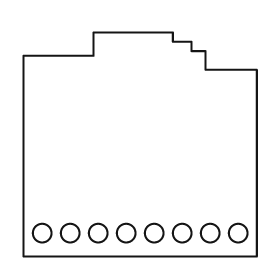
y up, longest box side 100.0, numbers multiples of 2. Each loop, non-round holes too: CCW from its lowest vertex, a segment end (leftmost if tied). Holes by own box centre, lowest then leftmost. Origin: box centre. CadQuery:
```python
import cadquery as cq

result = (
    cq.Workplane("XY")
    .moveTo(-50.0, -48.0)
    .lineTo(50.0, -48.0)
    .lineTo(50.0, 32.0)
    .lineTo(28.0, 32.0)
    .lineTo(28.0, 40.0)
    .lineTo(22.0, 40.0)
    .lineTo(22.0, 44.0)
    .lineTo(14.0, 44.0)
    .lineTo(14.0, 48.0)
    .lineTo(-20.0, 48.0)
    .lineTo(-20.0, 38.0)
    .lineTo(-50.0, 38.0)
    .close()
    .moveTo(-42.0, -38.0)
    .circle(4.0)
    .moveTo(-30.0, -38.0)
    .circle(4.0)
    .moveTo(-18.0, -38.0)
    .circle(4.0)
    .moveTo(-6.0, -38.0)
    .circle(4.0)
    .moveTo(6.0, -38.0)
    .circle(4.0)
    .moveTo(18.0, -38.0)
    .circle(4.0)
    .moveTo(30.0, -38.0)
    .circle(4.0)
    .moveTo(42.0, -38.0)
    .circle(4.0)
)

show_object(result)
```